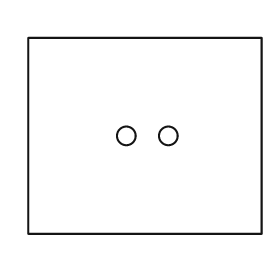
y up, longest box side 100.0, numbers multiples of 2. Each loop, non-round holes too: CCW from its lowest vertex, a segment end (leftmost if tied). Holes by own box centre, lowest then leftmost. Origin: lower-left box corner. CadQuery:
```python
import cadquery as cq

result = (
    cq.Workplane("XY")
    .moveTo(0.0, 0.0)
    .lineTo(100.0, 0.0)
    .lineTo(100.0, 84.0)
    .lineTo(0.0, 84.0)
    .close()
    .moveTo(42.0, 42.0)
    .circle(4.0)
    .moveTo(60.0, 42.0)
    .circle(4.0)
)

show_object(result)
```